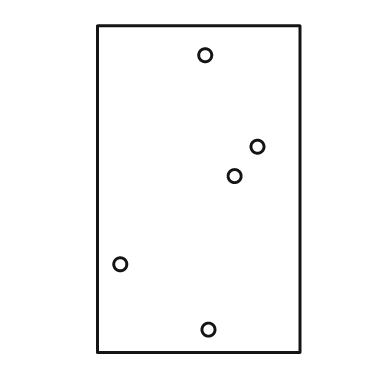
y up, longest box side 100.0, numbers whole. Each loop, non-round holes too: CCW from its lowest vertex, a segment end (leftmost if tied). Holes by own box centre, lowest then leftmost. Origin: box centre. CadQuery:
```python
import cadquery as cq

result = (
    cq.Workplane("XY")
    .moveTo(-31.0, -50.0)
    .lineTo(31.0, -50.0)
    .lineTo(31.0, 50.0)
    .lineTo(-31.0, 50.0)
    .close()
    .moveTo(3.0, -43.0)
    .circle(2.0)
    .moveTo(-24.0, -23.0)
    .circle(2.0)
    .moveTo(11.0, 4.0)
    .circle(2.0)
    .moveTo(18.0, 13.0)
    .circle(2.0)
    .moveTo(2.0, 41.0)
    .circle(2.0)
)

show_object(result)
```